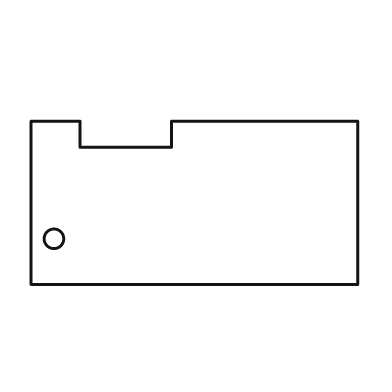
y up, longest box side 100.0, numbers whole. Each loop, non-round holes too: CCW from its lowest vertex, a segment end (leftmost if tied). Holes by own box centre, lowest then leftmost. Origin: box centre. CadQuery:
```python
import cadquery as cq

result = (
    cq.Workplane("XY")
    .moveTo(-50.0, -25.0)
    .lineTo(50.0, -25.0)
    .lineTo(50.0, 25.0)
    .lineTo(-7.0, 25.0)
    .lineTo(-7.0, 17.0)
    .lineTo(-35.0, 17.0)
    .lineTo(-35.0, 25.0)
    .lineTo(-50.0, 25.0)
    .close()
    .moveTo(-43.0, -11.0)
    .circle(3.0)
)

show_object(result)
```